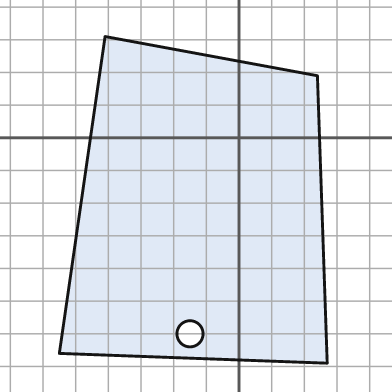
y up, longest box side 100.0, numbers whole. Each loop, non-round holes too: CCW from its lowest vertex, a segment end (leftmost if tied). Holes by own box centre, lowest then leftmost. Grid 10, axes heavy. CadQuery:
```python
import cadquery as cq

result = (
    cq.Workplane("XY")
    .moveTo(27.0, -69.0)
    .lineTo(24.0, 19.0)
    .lineTo(-41.0, 31.0)
    .lineTo(-55.0, -66.0)
    .close()
    .moveTo(-15.0, -60.0)
    .circle(4.0)
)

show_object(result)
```